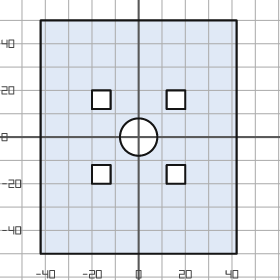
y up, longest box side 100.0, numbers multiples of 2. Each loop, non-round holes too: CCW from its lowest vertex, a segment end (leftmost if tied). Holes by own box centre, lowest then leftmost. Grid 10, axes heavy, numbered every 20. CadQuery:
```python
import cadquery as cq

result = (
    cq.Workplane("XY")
    .moveTo(-42.0, -50.0)
    .lineTo(42.0, -50.0)
    .lineTo(42.0, 50.0)
    .lineTo(-42.0, 50.0)
    .close()
    .moveTo(-20.0, -20.0)
    .lineTo(-12.0, -20.0)
    .lineTo(-12.0, -12.0)
    .lineTo(-20.0, -12.0)
    .close()
    .moveTo(12.0, -20.0)
    .lineTo(20.0, -20.0)
    .lineTo(20.0, -12.0)
    .lineTo(12.0, -12.0)
    .close()
    .moveTo(0.0, 0.0)
    .circle(8.0)
    .moveTo(-20.0, 12.0)
    .lineTo(-12.0, 12.0)
    .lineTo(-12.0, 20.0)
    .lineTo(-20.0, 20.0)
    .close()
    .moveTo(12.0, 12.0)
    .lineTo(20.0, 12.0)
    .lineTo(20.0, 20.0)
    .lineTo(12.0, 20.0)
    .close()
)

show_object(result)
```